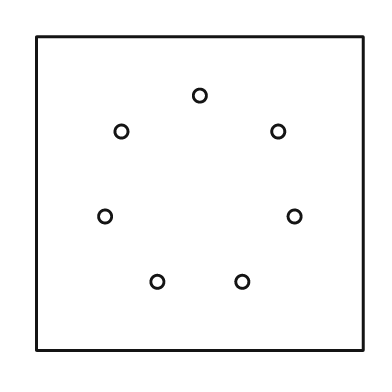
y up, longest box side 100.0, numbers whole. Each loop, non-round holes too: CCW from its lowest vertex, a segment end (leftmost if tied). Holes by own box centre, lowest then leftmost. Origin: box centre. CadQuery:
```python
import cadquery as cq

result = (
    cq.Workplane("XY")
    .moveTo(-50.0, -48.0)
    .lineTo(50.0, -48.0)
    .lineTo(50.0, 48.0)
    .lineTo(-50.0, 48.0)
    .close()
    .moveTo(-13.0, -27.0)
    .circle(2.0)
    .moveTo(13.0, -27.0)
    .circle(2.0)
    .moveTo(-29.0, -7.0)
    .circle(2.0)
    .moveTo(29.0, -7.0)
    .circle(2.0)
    .moveTo(-24.0, 19.0)
    .circle(2.0)
    .moveTo(24.0, 19.0)
    .circle(2.0)
    .moveTo(0.0, 30.0)
    .circle(2.0)
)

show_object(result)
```